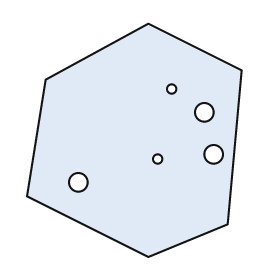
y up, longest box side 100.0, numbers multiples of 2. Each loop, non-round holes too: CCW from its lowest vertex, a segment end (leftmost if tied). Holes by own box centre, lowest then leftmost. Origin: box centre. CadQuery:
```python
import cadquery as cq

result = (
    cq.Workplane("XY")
    .moveTo(6.0, -50.0)
    .lineTo(40.0, -36.0)
    .lineTo(46.0, 30.0)
    .lineTo(6.0, 50.0)
    .lineTo(-38.0, 26.0)
    .lineTo(-46.0, -24.0)
    .close()
    .moveTo(-24.0, -18.0)
    .circle(4.0)
    .moveTo(10.0, -8.0)
    .circle(2.0)
    .moveTo(34.0, -6.0)
    .circle(4.0)
    .moveTo(30.0, 12.0)
    .circle(4.0)
    .moveTo(16.0, 22.0)
    .circle(2.0)
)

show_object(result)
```